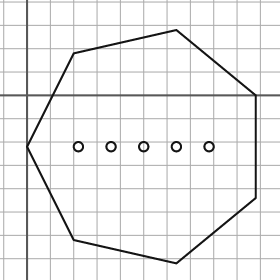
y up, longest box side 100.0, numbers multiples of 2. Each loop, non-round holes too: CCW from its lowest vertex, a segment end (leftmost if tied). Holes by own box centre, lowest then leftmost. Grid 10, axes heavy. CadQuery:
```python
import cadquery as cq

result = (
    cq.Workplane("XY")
    .moveTo(64.0, -72.0)
    .lineTo(98.0, -44.0)
    .lineTo(98.0, 0.0)
    .lineTo(64.0, 28.0)
    .lineTo(20.0, 18.0)
    .lineTo(0.0, -22.0)
    .lineTo(20.0, -62.0)
    .close()
    .moveTo(22.0, -22.0)
    .circle(2.0)
    .moveTo(36.0, -22.0)
    .circle(2.0)
    .moveTo(50.0, -22.0)
    .circle(2.0)
    .moveTo(64.0, -22.0)
    .circle(2.0)
    .moveTo(78.0, -22.0)
    .circle(2.0)
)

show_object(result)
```